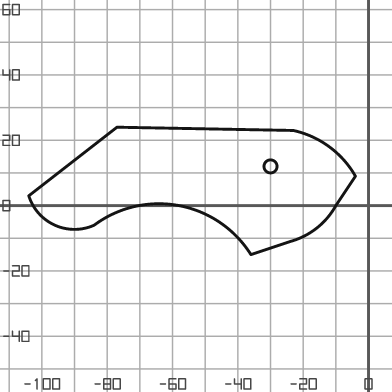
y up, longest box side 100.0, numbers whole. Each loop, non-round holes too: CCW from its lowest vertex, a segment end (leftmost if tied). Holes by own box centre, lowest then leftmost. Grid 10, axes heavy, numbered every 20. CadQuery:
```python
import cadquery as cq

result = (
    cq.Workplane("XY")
    .moveTo(-36.0, -15.0)
    .lineTo(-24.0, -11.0)
    .threePointArc((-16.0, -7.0), (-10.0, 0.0))
    .lineTo(-4.0, 9.0)
    .threePointArc((-12.0, 18.0), (-23.0, 23.0))
    .lineTo(-77.0, 24.0)
    .lineTo(-104.0, 3.0)
    .threePointArc((-96.0, -6.0), (-84.0, -6.0))
    .threePointArc((-58.0, 0.0), (-36.0, -15.0))
    .close()
    .moveTo(-30.0, 12.0)
    .circle(2.0)
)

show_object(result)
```